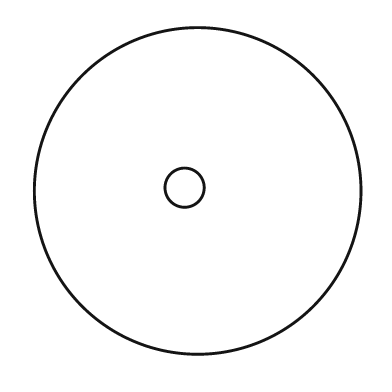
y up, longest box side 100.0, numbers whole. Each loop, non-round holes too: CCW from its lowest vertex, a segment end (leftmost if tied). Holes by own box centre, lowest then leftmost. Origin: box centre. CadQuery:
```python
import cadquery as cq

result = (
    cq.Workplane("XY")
    .moveTo(0.0, 0.0)
    .circle(50.0)
    .moveTo(-4.0, 1.0)
    .circle(6.0)
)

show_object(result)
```